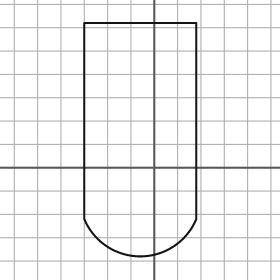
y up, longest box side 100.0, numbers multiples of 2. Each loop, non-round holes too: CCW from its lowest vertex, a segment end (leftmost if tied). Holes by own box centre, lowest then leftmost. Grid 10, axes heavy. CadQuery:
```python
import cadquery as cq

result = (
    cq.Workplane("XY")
    .moveTo(-30.0, -22.0)
    .threePointArc((-6.0, -38.0), (18.0, -22.0))
    .lineTo(18.0, 62.0)
    .lineTo(-30.0, 62.0)
    .close()
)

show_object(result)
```